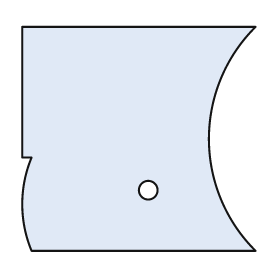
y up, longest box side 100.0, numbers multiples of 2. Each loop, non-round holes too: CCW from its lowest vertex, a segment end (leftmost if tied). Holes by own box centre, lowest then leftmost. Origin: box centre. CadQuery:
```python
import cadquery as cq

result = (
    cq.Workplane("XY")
    .moveTo(-46.0, -48.0)
    .lineTo(50.0, -48.0)
    .threePointArc((30.0, 0.0), (50.0, 48.0))
    .lineTo(-50.0, 48.0)
    .lineTo(-50.0, -8.0)
    .lineTo(-46.0, -8.0)
    .threePointArc((-50.0, -28.0), (-46.0, -48.0))
    .close()
    .moveTo(4.0, -22.0)
    .circle(4.0)
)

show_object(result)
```